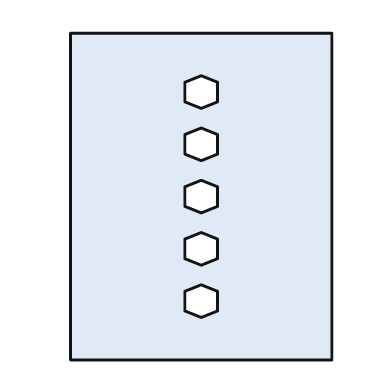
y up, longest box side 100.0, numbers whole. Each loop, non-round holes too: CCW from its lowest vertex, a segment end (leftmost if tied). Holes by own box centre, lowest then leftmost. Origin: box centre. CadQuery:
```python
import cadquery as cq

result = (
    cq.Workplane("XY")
    .moveTo(-40.0, -50.0)
    .lineTo(40.0, -50.0)
    .lineTo(40.0, 50.0)
    .lineTo(-40.0, 50.0)
    .close()
    .moveTo(0.0, -37.0)
    .lineTo(5.0, -35.0)
    .lineTo(5.0, -29.0)
    .lineTo(0.0, -27.0)
    .lineTo(-5.0, -29.0)
    .lineTo(-5.0, -35.0)
    .close()
    .moveTo(0.0, -21.0)
    .lineTo(5.0, -19.0)
    .lineTo(5.0, -13.0)
    .lineTo(0.0, -11.0)
    .lineTo(-5.0, -13.0)
    .lineTo(-5.0, -19.0)
    .close()
    .moveTo(0.0, -5.0)
    .lineTo(5.0, -3.0)
    .lineTo(5.0, 3.0)
    .lineTo(0.0, 5.0)
    .lineTo(-5.0, 3.0)
    .lineTo(-5.0, -3.0)
    .close()
    .moveTo(0.0, 11.0)
    .lineTo(5.0, 13.0)
    .lineTo(5.0, 19.0)
    .lineTo(0.0, 21.0)
    .lineTo(-5.0, 19.0)
    .lineTo(-5.0, 13.0)
    .close()
    .moveTo(0.0, 27.0)
    .lineTo(5.0, 29.0)
    .lineTo(5.0, 35.0)
    .lineTo(0.0, 37.0)
    .lineTo(-5.0, 35.0)
    .lineTo(-5.0, 29.0)
    .close()
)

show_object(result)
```